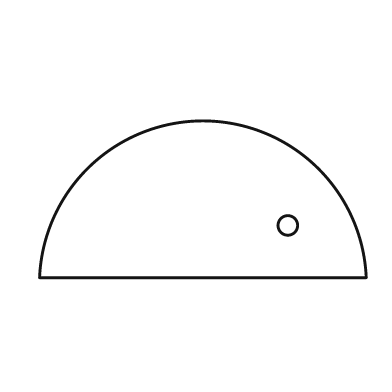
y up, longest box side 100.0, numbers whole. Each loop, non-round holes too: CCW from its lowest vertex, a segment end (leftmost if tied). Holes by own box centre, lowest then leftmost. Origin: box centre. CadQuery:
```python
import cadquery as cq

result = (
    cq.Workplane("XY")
    .moveTo(-50.0, -24.0)
    .lineTo(50.0, -24.0)
    .threePointArc((0.0, 24.0), (-50.0, -24.0))
    .close()
    .moveTo(26.0, -8.0)
    .circle(3.0)
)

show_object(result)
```